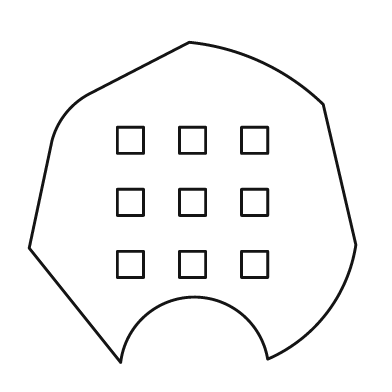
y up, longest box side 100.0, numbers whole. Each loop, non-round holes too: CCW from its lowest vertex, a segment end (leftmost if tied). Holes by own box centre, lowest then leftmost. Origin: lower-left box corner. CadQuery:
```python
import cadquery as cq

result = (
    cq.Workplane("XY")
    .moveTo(28.0, 0.0)
    .threePointArc((50.0, 20.0), (73.0, 1.0))
    .threePointArc((91.0, 15.0), (100.0, 36.0))
    .lineTo(90.0, 79.0)
    .threePointArc((71.0, 92.0), (49.0, 98.0))
    .lineTo(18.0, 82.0)
    .threePointArc((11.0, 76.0), (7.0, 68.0))
    .lineTo(0.0, 35.0)
    .close()
    .moveTo(27.0, 26.0)
    .lineTo(35.0, 26.0)
    .lineTo(35.0, 34.0)
    .lineTo(27.0, 34.0)
    .close()
    .moveTo(46.0, 26.0)
    .lineTo(54.0, 26.0)
    .lineTo(54.0, 34.0)
    .lineTo(46.0, 34.0)
    .close()
    .moveTo(65.0, 26.0)
    .lineTo(73.0, 26.0)
    .lineTo(73.0, 34.0)
    .lineTo(65.0, 34.0)
    .close()
    .moveTo(27.0, 45.0)
    .lineTo(35.0, 45.0)
    .lineTo(35.0, 53.0)
    .lineTo(27.0, 53.0)
    .close()
    .moveTo(46.0, 45.0)
    .lineTo(54.0, 45.0)
    .lineTo(54.0, 53.0)
    .lineTo(46.0, 53.0)
    .close()
    .moveTo(65.0, 45.0)
    .lineTo(73.0, 45.0)
    .lineTo(73.0, 53.0)
    .lineTo(65.0, 53.0)
    .close()
    .moveTo(27.0, 64.0)
    .lineTo(35.0, 64.0)
    .lineTo(35.0, 72.0)
    .lineTo(27.0, 72.0)
    .close()
    .moveTo(46.0, 64.0)
    .lineTo(54.0, 64.0)
    .lineTo(54.0, 72.0)
    .lineTo(46.0, 72.0)
    .close()
    .moveTo(65.0, 64.0)
    .lineTo(73.0, 64.0)
    .lineTo(73.0, 72.0)
    .lineTo(65.0, 72.0)
    .close()
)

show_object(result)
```